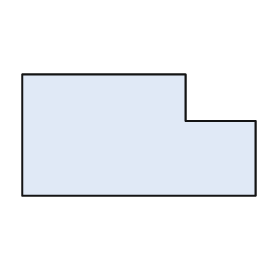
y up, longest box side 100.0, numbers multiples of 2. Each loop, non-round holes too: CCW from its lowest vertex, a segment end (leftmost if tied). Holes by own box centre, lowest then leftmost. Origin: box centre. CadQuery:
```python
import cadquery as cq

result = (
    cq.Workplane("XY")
    .moveTo(-50.0, -26.0)
    .lineTo(50.0, -26.0)
    .lineTo(50.0, 6.0)
    .lineTo(20.0, 6.0)
    .lineTo(20.0, 26.0)
    .lineTo(-50.0, 26.0)
    .close()
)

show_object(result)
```